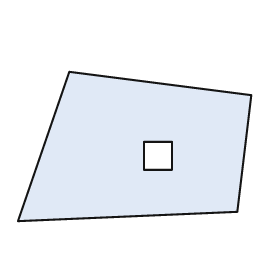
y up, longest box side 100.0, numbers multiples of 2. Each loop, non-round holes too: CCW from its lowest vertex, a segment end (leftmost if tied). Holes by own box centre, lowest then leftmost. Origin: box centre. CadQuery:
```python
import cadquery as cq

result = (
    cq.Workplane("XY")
    .moveTo(-50.0, -32.0)
    .lineTo(44.0, -28.0)
    .lineTo(50.0, 22.0)
    .lineTo(-28.0, 32.0)
    .close()
    .moveTo(4.0, -10.0)
    .lineTo(16.0, -10.0)
    .lineTo(16.0, 2.0)
    .lineTo(4.0, 2.0)
    .close()
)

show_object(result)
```